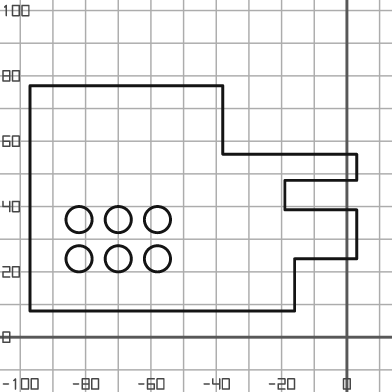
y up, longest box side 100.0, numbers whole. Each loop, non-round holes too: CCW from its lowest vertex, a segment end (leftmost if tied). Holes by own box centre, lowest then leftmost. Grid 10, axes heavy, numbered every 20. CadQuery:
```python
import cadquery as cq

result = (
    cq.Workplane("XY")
    .moveTo(-97.0, 8.0)
    .lineTo(-16.0, 8.0)
    .lineTo(-16.0, 24.0)
    .lineTo(3.0, 24.0)
    .lineTo(3.0, 39.0)
    .lineTo(-19.0, 39.0)
    .lineTo(-19.0, 48.0)
    .lineTo(3.0, 48.0)
    .lineTo(3.0, 56.0)
    .lineTo(-38.0, 56.0)
    .lineTo(-38.0, 77.0)
    .lineTo(-97.0, 77.0)
    .close()
    .moveTo(-82.0, 24.0)
    .circle(4.0)
    .moveTo(-70.0, 24.0)
    .circle(4.0)
    .moveTo(-58.0, 24.0)
    .circle(4.0)
    .moveTo(-82.0, 36.0)
    .circle(4.0)
    .moveTo(-70.0, 36.0)
    .circle(4.0)
    .moveTo(-58.0, 36.0)
    .circle(4.0)
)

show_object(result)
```